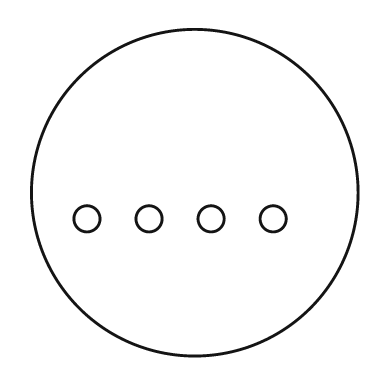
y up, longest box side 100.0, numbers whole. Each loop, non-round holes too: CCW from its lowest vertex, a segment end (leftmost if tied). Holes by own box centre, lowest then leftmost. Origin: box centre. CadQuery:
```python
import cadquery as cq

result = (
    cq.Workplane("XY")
    .moveTo(0.0, 0.0)
    .circle(50.0)
    .moveTo(-33.0, -8.0)
    .circle(4.0)
    .moveTo(-14.0, -8.0)
    .circle(4.0)
    .moveTo(5.0, -8.0)
    .circle(4.0)
    .moveTo(24.0, -8.0)
    .circle(4.0)
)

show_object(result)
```